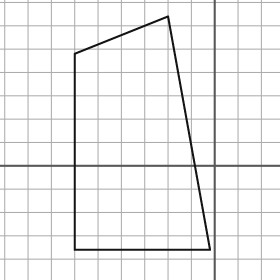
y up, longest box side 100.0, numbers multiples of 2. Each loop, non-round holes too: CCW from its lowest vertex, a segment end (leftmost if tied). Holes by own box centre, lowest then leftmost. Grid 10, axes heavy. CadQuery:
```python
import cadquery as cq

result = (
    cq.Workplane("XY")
    .moveTo(-60.0, -36.0)
    .lineTo(-2.0, -36.0)
    .lineTo(-20.0, 64.0)
    .lineTo(-60.0, 48.0)
    .close()
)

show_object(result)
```